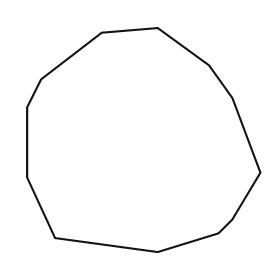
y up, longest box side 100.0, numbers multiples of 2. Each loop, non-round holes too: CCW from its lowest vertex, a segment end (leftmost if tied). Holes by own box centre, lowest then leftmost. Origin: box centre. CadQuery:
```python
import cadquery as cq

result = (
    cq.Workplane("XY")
    .moveTo(6.0, -48.0)
    .lineTo(32.0, -40.0)
    .lineTo(38.0, -34.0)
    .lineTo(50.0, -14.0)
    .lineTo(38.0, 18.0)
    .lineTo(28.0, 32.0)
    .lineTo(6.0, 48.0)
    .lineTo(-18.0, 46.0)
    .lineTo(-44.0, 26.0)
    .lineTo(-50.0, 14.0)
    .lineTo(-50.0, -16.0)
    .lineTo(-38.0, -42.0)
    .close()
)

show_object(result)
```